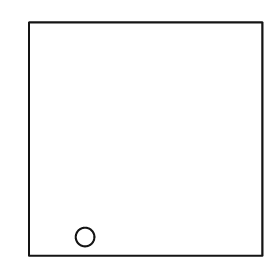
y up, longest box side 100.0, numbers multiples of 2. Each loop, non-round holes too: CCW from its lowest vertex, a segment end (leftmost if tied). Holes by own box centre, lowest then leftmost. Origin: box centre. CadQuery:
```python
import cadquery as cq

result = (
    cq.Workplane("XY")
    .moveTo(-50.0, -50.0)
    .lineTo(50.0, -50.0)
    .lineTo(50.0, 50.0)
    .lineTo(-50.0, 50.0)
    .close()
    .moveTo(-26.0, -42.0)
    .circle(4.0)
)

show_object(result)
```